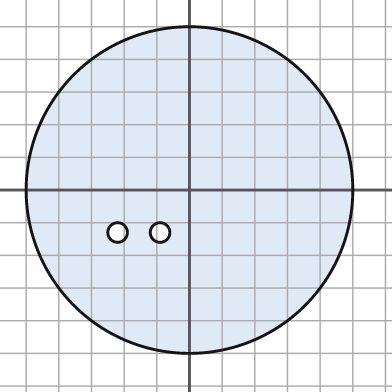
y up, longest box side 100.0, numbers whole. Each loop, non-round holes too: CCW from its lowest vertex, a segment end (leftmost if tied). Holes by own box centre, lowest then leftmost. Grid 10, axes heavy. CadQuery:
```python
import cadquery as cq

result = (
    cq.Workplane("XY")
    .moveTo(0.0, 0.0)
    .circle(50.0)
    .moveTo(-22.0, -13.0)
    .circle(3.0)
    .moveTo(-9.0, -13.0)
    .circle(3.0)
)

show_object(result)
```